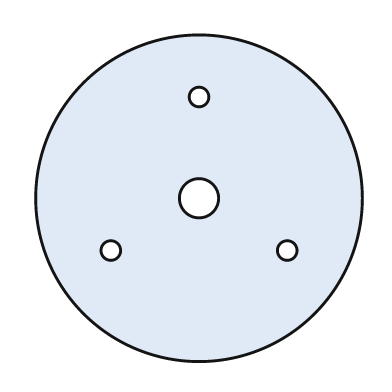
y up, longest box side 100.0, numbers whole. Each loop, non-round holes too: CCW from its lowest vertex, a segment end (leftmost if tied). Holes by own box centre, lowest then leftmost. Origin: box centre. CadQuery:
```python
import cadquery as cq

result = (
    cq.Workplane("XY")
    .moveTo(0.0, 0.0)
    .circle(50.0)
    .moveTo(-27.0, -16.0)
    .circle(3.0)
    .moveTo(27.0, -16.0)
    .circle(3.0)
    .moveTo(0.0, 0.0)
    .circle(6.0)
    .moveTo(0.0, 31.0)
    .circle(3.0)
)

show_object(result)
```